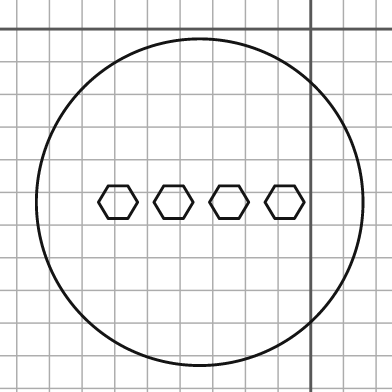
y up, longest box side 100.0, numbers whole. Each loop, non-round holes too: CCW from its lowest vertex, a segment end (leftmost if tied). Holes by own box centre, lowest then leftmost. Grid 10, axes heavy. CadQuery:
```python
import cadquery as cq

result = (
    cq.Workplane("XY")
    .moveTo(-34.0, -53.0)
    .circle(50.0)
    .moveTo(-62.0, -58.0)
    .lineTo(-56.0, -58.0)
    .lineTo(-53.0, -53.0)
    .lineTo(-56.0, -48.0)
    .lineTo(-62.0, -48.0)
    .lineTo(-65.0, -53.0)
    .close()
    .moveTo(-45.0, -58.0)
    .lineTo(-39.0, -58.0)
    .lineTo(-36.0, -53.0)
    .lineTo(-39.0, -48.0)
    .lineTo(-45.0, -48.0)
    .lineTo(-48.0, -53.0)
    .close()
    .moveTo(-28.0, -58.0)
    .lineTo(-22.0, -58.0)
    .lineTo(-19.0, -53.0)
    .lineTo(-22.0, -48.0)
    .lineTo(-28.0, -48.0)
    .lineTo(-31.0, -53.0)
    .close()
    .moveTo(-11.0, -58.0)
    .lineTo(-5.0, -58.0)
    .lineTo(-2.0, -53.0)
    .lineTo(-5.0, -48.0)
    .lineTo(-11.0, -48.0)
    .lineTo(-14.0, -53.0)
    .close()
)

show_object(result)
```